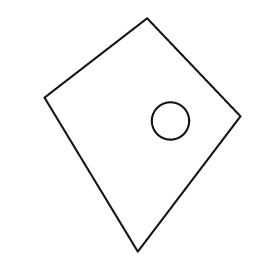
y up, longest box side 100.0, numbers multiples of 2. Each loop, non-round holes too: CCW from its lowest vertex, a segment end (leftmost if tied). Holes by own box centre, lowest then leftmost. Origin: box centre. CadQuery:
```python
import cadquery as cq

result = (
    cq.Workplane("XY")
    .moveTo(-2.0, -50.0)
    .lineTo(42.0, 8.0)
    .lineTo(2.0, 50.0)
    .lineTo(-42.0, 16.0)
    .close()
    .moveTo(12.0, 6.0)
    .circle(8.0)
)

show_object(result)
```